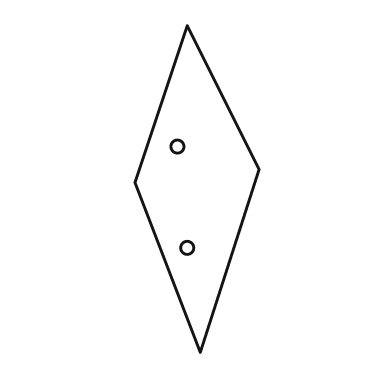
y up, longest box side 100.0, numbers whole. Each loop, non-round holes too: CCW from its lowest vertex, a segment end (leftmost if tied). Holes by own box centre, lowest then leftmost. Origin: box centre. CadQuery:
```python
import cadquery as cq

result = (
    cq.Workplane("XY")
    .moveTo(1.0, -50.0)
    .lineTo(19.0, 6.0)
    .lineTo(-3.0, 50.0)
    .lineTo(-19.0, 2.0)
    .close()
    .moveTo(-3.0, -18.0)
    .circle(2.0)
    .moveTo(-6.0, 13.0)
    .circle(2.0)
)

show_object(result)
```